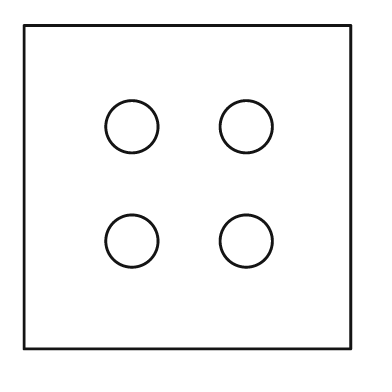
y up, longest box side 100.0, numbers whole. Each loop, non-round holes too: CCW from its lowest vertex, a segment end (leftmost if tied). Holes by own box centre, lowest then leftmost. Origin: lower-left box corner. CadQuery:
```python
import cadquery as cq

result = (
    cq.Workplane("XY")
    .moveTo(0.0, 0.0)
    .lineTo(100.0, 0.0)
    .lineTo(100.0, 99.0)
    .lineTo(0.0, 99.0)
    .close()
    .moveTo(33.0, 33.0)
    .circle(8.0)
    .moveTo(68.0, 33.0)
    .circle(8.0)
    .moveTo(33.0, 68.0)
    .circle(8.0)
    .moveTo(68.0, 68.0)
    .circle(8.0)
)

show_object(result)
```